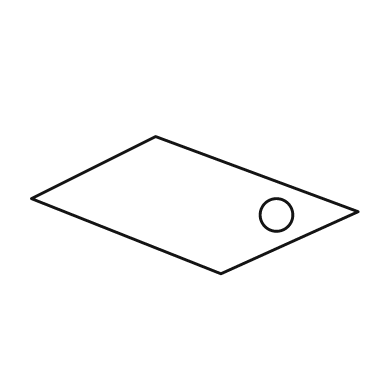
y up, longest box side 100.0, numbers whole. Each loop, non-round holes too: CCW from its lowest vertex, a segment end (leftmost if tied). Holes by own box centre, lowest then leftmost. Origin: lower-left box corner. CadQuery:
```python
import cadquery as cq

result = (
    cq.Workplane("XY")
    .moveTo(58.0, 0.0)
    .lineTo(100.0, 19.0)
    .lineTo(38.0, 42.0)
    .lineTo(0.0, 23.0)
    .close()
    .moveTo(75.0, 18.0)
    .circle(5.0)
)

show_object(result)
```